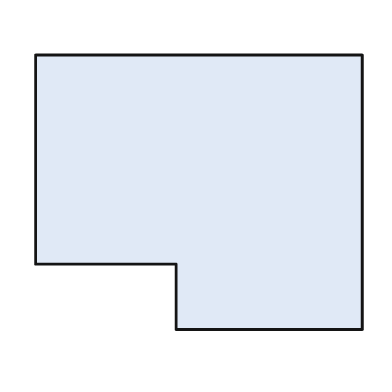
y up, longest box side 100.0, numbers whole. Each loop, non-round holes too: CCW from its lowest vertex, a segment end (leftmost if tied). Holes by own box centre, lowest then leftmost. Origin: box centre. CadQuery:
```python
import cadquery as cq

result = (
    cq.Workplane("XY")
    .moveTo(-7.0, -42.0)
    .lineTo(50.0, -42.0)
    .lineTo(50.0, 42.0)
    .lineTo(-50.0, 42.0)
    .lineTo(-50.0, -22.0)
    .lineTo(-7.0, -22.0)
    .close()
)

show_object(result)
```